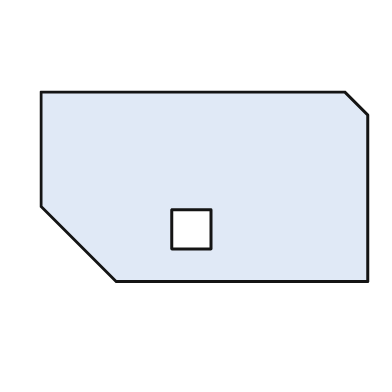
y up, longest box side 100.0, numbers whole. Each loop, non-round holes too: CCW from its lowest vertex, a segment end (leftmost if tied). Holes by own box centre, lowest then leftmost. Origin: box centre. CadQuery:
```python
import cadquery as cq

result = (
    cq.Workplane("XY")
    .moveTo(-27.0, -29.0)
    .lineTo(50.0, -29.0)
    .lineTo(50.0, 22.0)
    .lineTo(43.0, 29.0)
    .lineTo(-50.0, 29.0)
    .lineTo(-50.0, -6.0)
    .close()
    .moveTo(-10.0, -19.0)
    .lineTo(2.0, -19.0)
    .lineTo(2.0, -7.0)
    .lineTo(-10.0, -7.0)
    .close()
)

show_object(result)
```